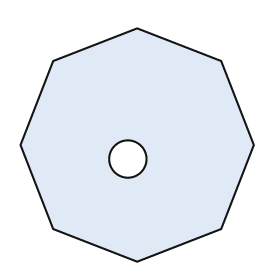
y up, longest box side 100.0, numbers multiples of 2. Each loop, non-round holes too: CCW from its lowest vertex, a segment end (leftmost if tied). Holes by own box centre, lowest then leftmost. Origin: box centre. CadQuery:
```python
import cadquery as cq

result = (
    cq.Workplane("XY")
    .moveTo(0.0, -50.0)
    .lineTo(36.0, -36.0)
    .lineTo(50.0, 0.0)
    .lineTo(36.0, 36.0)
    .lineTo(0.0, 50.0)
    .lineTo(-36.0, 36.0)
    .lineTo(-50.0, 0.0)
    .lineTo(-36.0, -36.0)
    .close()
    .moveTo(-4.0, -6.0)
    .circle(8.0)
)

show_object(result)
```